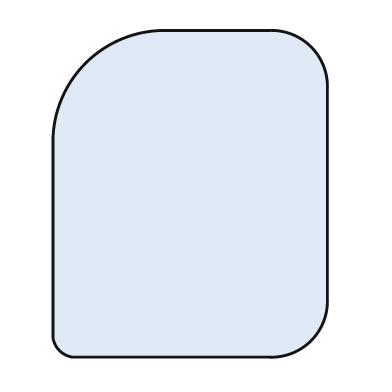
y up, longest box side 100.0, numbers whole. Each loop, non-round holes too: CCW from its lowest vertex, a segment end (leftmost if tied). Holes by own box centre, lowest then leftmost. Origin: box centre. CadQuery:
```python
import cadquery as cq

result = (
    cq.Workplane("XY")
    .moveTo(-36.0, -50.0)
    .lineTo(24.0, -50.0)
    .threePointArc((37.0, -45.0), (42.0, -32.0))
    .lineTo(42.0, 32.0)
    .threePointArc((37.0, 45.0), (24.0, 50.0))
    .lineTo(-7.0, 50.0)
    .threePointArc((-32.0, 40.0), (-42.0, 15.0))
    .lineTo(-42.0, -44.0)
    .threePointArc((-40.0, -48.0), (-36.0, -50.0))
    .close()
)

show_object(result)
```